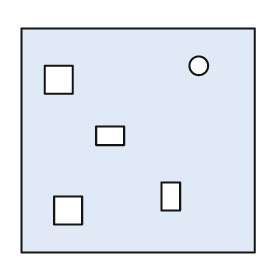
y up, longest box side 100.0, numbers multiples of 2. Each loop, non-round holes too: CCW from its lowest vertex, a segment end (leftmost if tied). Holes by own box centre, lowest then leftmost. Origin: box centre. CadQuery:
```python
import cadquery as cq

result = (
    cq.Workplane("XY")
    .moveTo(-50.0, -48.0)
    .lineTo(50.0, -48.0)
    .lineTo(50.0, 48.0)
    .lineTo(-50.0, 48.0)
    .close()
    .moveTo(-36.0, -36.0)
    .lineTo(-24.0, -36.0)
    .lineTo(-24.0, -24.0)
    .lineTo(-36.0, -24.0)
    .close()
    .moveTo(10.0, -30.0)
    .lineTo(18.0, -30.0)
    .lineTo(18.0, -18.0)
    .lineTo(10.0, -18.0)
    .close()
    .moveTo(-18.0, -2.0)
    .lineTo(-6.0, -2.0)
    .lineTo(-6.0, 6.0)
    .lineTo(-18.0, 6.0)
    .close()
    .moveTo(-40.0, 20.0)
    .lineTo(-28.0, 20.0)
    .lineTo(-28.0, 32.0)
    .lineTo(-40.0, 32.0)
    .close()
    .moveTo(26.0, 32.0)
    .circle(4.0)
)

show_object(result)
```